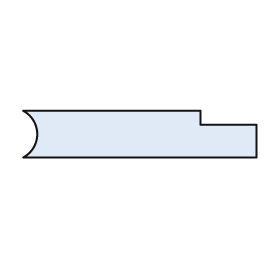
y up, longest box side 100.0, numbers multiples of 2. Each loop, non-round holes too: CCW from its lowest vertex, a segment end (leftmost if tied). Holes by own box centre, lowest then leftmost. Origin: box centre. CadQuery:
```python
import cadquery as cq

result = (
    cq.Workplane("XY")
    .moveTo(-50.0, -10.0)
    .lineTo(50.0, -10.0)
    .lineTo(50.0, 4.0)
    .lineTo(26.0, 4.0)
    .lineTo(26.0, 10.0)
    .lineTo(-50.0, 10.0)
    .threePointArc((-44.0, 0.0), (-50.0, -10.0))
    .close()
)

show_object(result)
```